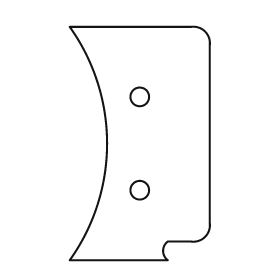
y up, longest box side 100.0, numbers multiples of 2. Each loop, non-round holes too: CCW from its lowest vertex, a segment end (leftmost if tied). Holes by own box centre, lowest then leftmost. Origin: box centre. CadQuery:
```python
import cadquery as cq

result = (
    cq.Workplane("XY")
    .moveTo(-30.0, -50.0)
    .lineTo(12.0, -50.0)
    .threePointArc((10.0, -46.0), (12.0, -42.0))
    .lineTo(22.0, -42.0)
    .threePointArc((28.0, -40.0), (30.0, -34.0))
    .lineTo(30.0, 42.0)
    .threePointArc((28.0, 48.0), (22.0, 50.0))
    .lineTo(-30.0, 50.0)
    .threePointArc((-14.0, 0.0), (-30.0, -50.0))
    .close()
    .moveTo(0.0, -20.0)
    .circle(4.0)
    .moveTo(0.0, 20.0)
    .circle(4.0)
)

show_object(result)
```